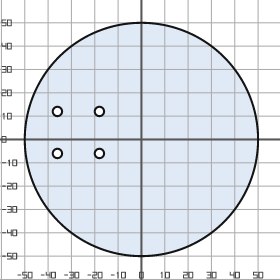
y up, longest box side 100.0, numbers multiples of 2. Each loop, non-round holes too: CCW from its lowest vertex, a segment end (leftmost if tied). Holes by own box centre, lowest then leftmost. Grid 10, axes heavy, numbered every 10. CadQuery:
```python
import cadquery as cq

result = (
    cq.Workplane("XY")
    .moveTo(0.0, 0.0)
    .circle(50.0)
    .moveTo(-36.0, -6.0)
    .circle(2.0)
    .moveTo(-18.0, -6.0)
    .circle(2.0)
    .moveTo(-36.0, 12.0)
    .circle(2.0)
    .moveTo(-18.0, 12.0)
    .circle(2.0)
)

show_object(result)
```